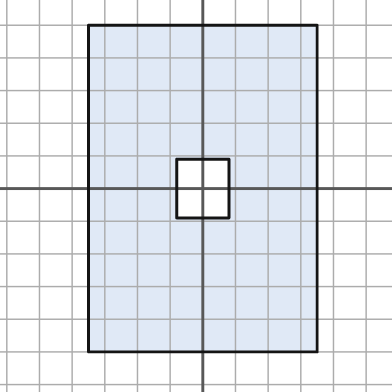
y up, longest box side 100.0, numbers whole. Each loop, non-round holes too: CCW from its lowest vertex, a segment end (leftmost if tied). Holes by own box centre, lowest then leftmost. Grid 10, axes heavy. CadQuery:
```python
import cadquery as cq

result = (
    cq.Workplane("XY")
    .moveTo(-35.0, -50.0)
    .lineTo(35.0, -50.0)
    .lineTo(35.0, 50.0)
    .lineTo(-35.0, 50.0)
    .close()
    .moveTo(-8.0, -9.0)
    .lineTo(8.0, -9.0)
    .lineTo(8.0, 9.0)
    .lineTo(-8.0, 9.0)
    .close()
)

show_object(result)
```